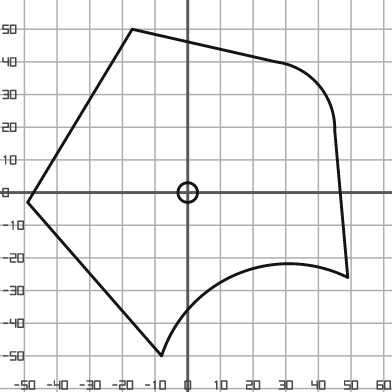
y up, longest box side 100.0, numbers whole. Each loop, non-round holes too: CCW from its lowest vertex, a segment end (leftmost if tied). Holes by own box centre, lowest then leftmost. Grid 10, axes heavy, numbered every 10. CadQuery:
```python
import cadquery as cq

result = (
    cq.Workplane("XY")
    .moveTo(-8.0, -50.0)
    .threePointArc((15.0, -25.0), (49.0, -26.0))
    .lineTo(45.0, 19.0)
    .threePointArc((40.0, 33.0), (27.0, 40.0))
    .lineTo(-17.0, 50.0)
    .lineTo(-49.0, -3.0)
    .close()
    .moveTo(0.0, 0.0)
    .circle(3.0)
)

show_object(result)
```